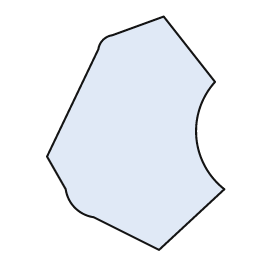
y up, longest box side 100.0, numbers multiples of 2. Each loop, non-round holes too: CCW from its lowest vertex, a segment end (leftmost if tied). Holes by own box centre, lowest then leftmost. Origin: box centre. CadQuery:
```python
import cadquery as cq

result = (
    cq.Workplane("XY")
    .moveTo(10.0, -50.0)
    .lineTo(38.0, -24.0)
    .threePointArc((26.0, -2.0), (34.0, 22.0))
    .lineTo(12.0, 50.0)
    .lineTo(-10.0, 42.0)
    .threePointArc((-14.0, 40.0), (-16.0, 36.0))
    .lineTo(-38.0, -10.0)
    .lineTo(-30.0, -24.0)
    .threePointArc((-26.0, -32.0), (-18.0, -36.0))
    .close()
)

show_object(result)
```